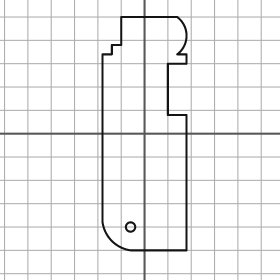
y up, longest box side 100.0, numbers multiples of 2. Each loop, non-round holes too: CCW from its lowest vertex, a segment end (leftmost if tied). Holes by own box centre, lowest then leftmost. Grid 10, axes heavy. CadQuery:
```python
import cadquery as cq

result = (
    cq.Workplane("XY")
    .moveTo(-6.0, -50.0)
    .lineTo(18.0, -50.0)
    .lineTo(18.0, 8.0)
    .lineTo(10.0, 8.0)
    .lineTo(10.0, 30.0)
    .lineTo(18.0, 30.0)
    .lineTo(18.0, 34.0)
    .lineTo(14.0, 34.0)
    .threePointArc((18.0, 42.0), (14.0, 50.0))
    .lineTo(-10.0, 50.0)
    .lineTo(-10.0, 38.0)
    .lineTo(-14.0, 38.0)
    .lineTo(-14.0, 34.0)
    .lineTo(-18.0, 34.0)
    .lineTo(-18.0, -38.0)
    .threePointArc((-14.0, -46.0), (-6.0, -50.0))
    .close()
    .moveTo(-6.0, -40.0)
    .circle(2.0)
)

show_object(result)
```